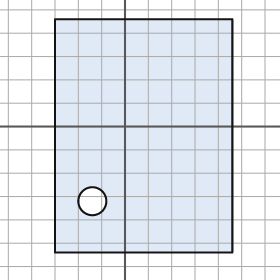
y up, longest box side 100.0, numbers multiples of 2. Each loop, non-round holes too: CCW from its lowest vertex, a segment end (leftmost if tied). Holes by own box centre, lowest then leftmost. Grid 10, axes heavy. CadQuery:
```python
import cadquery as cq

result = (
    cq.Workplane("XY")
    .moveTo(-30.0, -54.0)
    .lineTo(46.0, -54.0)
    .lineTo(46.0, 46.0)
    .lineTo(-30.0, 46.0)
    .close()
    .moveTo(-14.0, -32.0)
    .circle(6.0)
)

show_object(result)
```